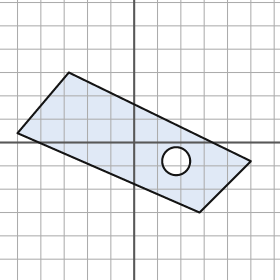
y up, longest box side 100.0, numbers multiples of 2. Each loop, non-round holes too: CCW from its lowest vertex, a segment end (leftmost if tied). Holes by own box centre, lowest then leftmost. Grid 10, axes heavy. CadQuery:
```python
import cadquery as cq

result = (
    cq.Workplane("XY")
    .moveTo(28.0, -30.0)
    .lineTo(50.0, -8.0)
    .lineTo(-28.0, 30.0)
    .lineTo(-50.0, 4.0)
    .close()
    .moveTo(18.0, -8.0)
    .circle(6.0)
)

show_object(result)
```